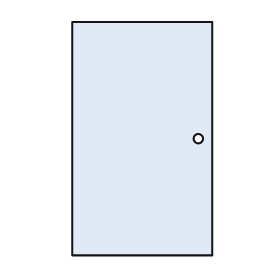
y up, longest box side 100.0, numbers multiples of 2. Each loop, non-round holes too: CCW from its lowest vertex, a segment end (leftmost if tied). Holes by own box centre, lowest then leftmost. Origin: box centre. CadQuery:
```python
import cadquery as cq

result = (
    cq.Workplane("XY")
    .moveTo(-30.0, -50.0)
    .lineTo(30.0, -50.0)
    .lineTo(30.0, 50.0)
    .lineTo(-30.0, 50.0)
    .close()
    .moveTo(24.0, 0.0)
    .circle(2.0)
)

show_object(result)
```